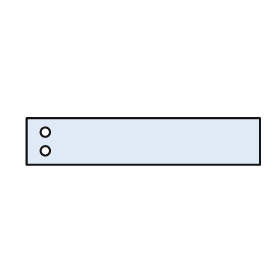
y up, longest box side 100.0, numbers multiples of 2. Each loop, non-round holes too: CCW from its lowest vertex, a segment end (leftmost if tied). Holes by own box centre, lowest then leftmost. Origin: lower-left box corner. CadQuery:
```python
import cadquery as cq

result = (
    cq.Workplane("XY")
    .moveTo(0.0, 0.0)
    .lineTo(100.0, 0.0)
    .lineTo(100.0, 20.0)
    .lineTo(0.0, 20.0)
    .close()
    .moveTo(8.0, 6.0)
    .circle(2.0)
    .moveTo(8.0, 14.0)
    .circle(2.0)
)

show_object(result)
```